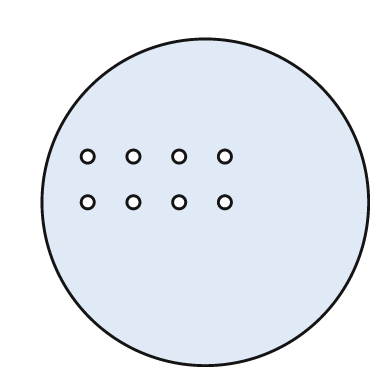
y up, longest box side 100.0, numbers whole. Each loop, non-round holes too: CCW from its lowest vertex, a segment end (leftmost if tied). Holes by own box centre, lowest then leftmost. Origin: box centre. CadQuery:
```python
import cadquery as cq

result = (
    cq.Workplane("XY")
    .moveTo(0.0, 0.0)
    .circle(50.0)
    .moveTo(-36.0, 0.0)
    .circle(2.0)
    .moveTo(-22.0, 0.0)
    .circle(2.0)
    .moveTo(-8.0, 0.0)
    .circle(2.0)
    .moveTo(6.0, 0.0)
    .circle(2.0)
    .moveTo(-36.0, 14.0)
    .circle(2.0)
    .moveTo(-22.0, 14.0)
    .circle(2.0)
    .moveTo(-8.0, 14.0)
    .circle(2.0)
    .moveTo(6.0, 14.0)
    .circle(2.0)
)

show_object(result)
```